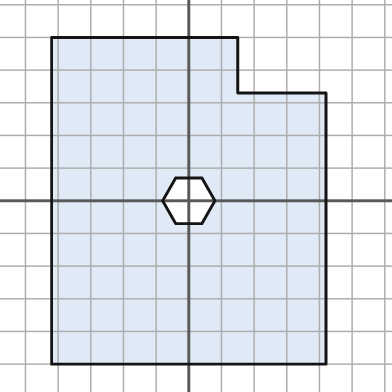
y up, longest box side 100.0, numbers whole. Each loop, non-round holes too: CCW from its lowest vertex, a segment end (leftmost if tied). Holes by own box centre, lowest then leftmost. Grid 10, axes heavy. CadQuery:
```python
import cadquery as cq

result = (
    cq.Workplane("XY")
    .moveTo(-42.0, -50.0)
    .lineTo(42.0, -50.0)
    .lineTo(42.0, 33.0)
    .lineTo(15.0, 33.0)
    .lineTo(15.0, 50.0)
    .lineTo(-42.0, 50.0)
    .close()
    .moveTo(-4.0, -7.0)
    .lineTo(4.0, -7.0)
    .lineTo(8.0, 0.0)
    .lineTo(4.0, 7.0)
    .lineTo(-4.0, 7.0)
    .lineTo(-8.0, 0.0)
    .close()
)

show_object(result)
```